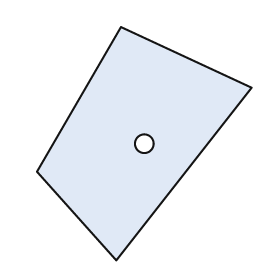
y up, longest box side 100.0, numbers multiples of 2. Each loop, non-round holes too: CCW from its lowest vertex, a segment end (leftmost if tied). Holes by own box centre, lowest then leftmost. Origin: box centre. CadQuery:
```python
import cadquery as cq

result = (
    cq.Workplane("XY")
    .moveTo(-12.0, -50.0)
    .lineTo(46.0, 24.0)
    .lineTo(-10.0, 50.0)
    .lineTo(-46.0, -12.0)
    .close()
    .moveTo(0.0, 0.0)
    .circle(4.0)
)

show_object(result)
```